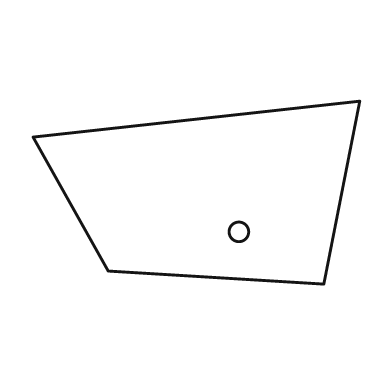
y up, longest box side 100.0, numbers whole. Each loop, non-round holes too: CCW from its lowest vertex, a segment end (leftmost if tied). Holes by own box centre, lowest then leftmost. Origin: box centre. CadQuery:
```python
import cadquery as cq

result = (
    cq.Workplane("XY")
    .moveTo(39.0, -28.0)
    .lineTo(50.0, 28.0)
    .lineTo(-50.0, 17.0)
    .lineTo(-27.0, -24.0)
    .close()
    .moveTo(13.0, -12.0)
    .circle(3.0)
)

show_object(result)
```